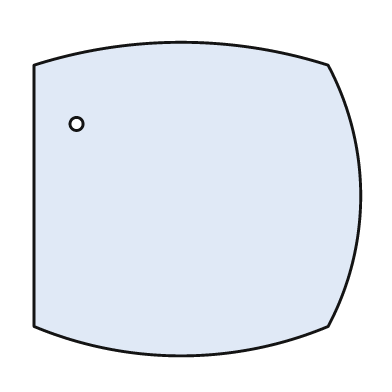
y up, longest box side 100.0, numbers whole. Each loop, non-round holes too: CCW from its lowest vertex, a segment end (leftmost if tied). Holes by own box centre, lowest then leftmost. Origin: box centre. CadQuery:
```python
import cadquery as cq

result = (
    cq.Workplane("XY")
    .moveTo(-50.0, -39.0)
    .threePointArc((-5.0, -48.0), (40.0, -39.0))
    .threePointArc((50.0, 1.0), (40.0, 41.0))
    .threePointArc((-5.0, 48.0), (-50.0, 41.0))
    .close()
    .moveTo(-37.0, 23.0)
    .circle(2.0)
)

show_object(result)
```